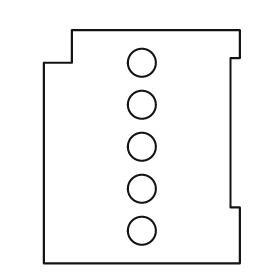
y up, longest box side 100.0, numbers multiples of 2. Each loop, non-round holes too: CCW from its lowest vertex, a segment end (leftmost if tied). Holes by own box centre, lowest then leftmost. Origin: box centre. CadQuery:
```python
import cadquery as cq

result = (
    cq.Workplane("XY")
    .moveTo(-42.0, -50.0)
    .lineTo(42.0, -50.0)
    .lineTo(42.0, -26.0)
    .lineTo(38.0, -26.0)
    .lineTo(38.0, 38.0)
    .lineTo(42.0, 38.0)
    .lineTo(42.0, 50.0)
    .lineTo(-30.0, 50.0)
    .lineTo(-30.0, 36.0)
    .lineTo(-42.0, 36.0)
    .close()
    .moveTo(0.0, -36.0)
    .circle(6.0)
    .moveTo(0.0, -18.0)
    .circle(6.0)
    .moveTo(0.0, 0.0)
    .circle(6.0)
    .moveTo(0.0, 18.0)
    .circle(6.0)
    .moveTo(0.0, 36.0)
    .circle(6.0)
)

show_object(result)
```